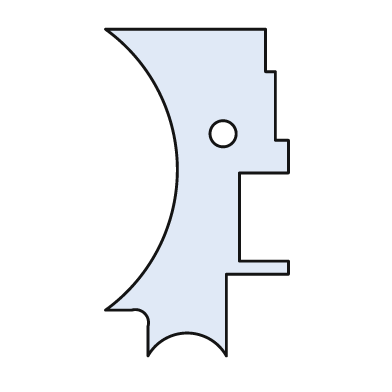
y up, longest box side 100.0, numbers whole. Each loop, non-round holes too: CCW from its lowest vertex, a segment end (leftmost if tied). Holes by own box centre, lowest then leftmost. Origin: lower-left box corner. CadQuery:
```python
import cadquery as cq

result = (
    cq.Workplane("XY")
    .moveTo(13.0, 0.0)
    .threePointArc((25.0, 7.0), (37.0, 0.0))
    .lineTo(37.0, 25.0)
    .lineTo(56.0, 25.0)
    .lineTo(56.0, 29.0)
    .lineTo(41.0, 29.0)
    .lineTo(41.0, 56.0)
    .lineTo(56.0, 56.0)
    .lineTo(56.0, 66.0)
    .lineTo(52.0, 66.0)
    .lineTo(52.0, 87.0)
    .lineTo(49.0, 87.0)
    .lineTo(49.0, 100.0)
    .lineTo(0.0, 100.0)
    .threePointArc((22.0, 57.0), (0.0, 14.0))
    .lineTo(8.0, 14.0)
    .threePointArc((12.0, 13.0), (13.0, 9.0))
    .close()
    .moveTo(36.0, 68.0)
    .circle(4.0)
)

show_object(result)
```